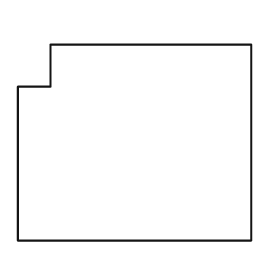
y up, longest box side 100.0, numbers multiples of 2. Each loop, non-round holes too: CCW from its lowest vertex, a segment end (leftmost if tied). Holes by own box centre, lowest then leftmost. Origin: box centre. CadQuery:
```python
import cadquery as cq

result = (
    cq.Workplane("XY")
    .moveTo(-50.0, -42.0)
    .lineTo(50.0, -42.0)
    .lineTo(50.0, 42.0)
    .lineTo(-36.0, 42.0)
    .lineTo(-36.0, 24.0)
    .lineTo(-50.0, 24.0)
    .close()
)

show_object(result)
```